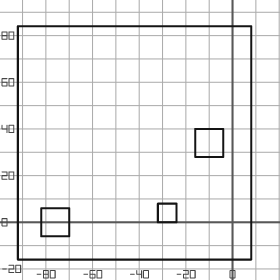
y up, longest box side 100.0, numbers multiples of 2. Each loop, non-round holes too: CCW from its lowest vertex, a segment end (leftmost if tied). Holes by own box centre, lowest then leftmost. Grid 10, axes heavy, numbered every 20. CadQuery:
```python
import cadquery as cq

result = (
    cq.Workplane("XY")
    .moveTo(-92.0, -16.0)
    .lineTo(8.0, -16.0)
    .lineTo(8.0, 84.0)
    .lineTo(-92.0, 84.0)
    .close()
    .moveTo(-82.0, -6.0)
    .lineTo(-70.0, -6.0)
    .lineTo(-70.0, 6.0)
    .lineTo(-82.0, 6.0)
    .close()
    .moveTo(-32.0, 0.0)
    .lineTo(-24.0, 0.0)
    .lineTo(-24.0, 8.0)
    .lineTo(-32.0, 8.0)
    .close()
    .moveTo(-16.0, 28.0)
    .lineTo(-4.0, 28.0)
    .lineTo(-4.0, 40.0)
    .lineTo(-16.0, 40.0)
    .close()
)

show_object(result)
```